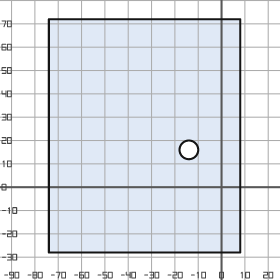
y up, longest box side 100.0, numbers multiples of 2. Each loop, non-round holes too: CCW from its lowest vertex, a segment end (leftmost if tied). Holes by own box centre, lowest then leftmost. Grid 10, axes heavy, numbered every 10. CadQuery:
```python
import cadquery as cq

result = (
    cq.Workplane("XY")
    .moveTo(-74.0, -28.0)
    .lineTo(8.0, -28.0)
    .lineTo(8.0, 72.0)
    .lineTo(-74.0, 72.0)
    .close()
    .moveTo(-14.0, 16.0)
    .circle(4.0)
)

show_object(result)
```